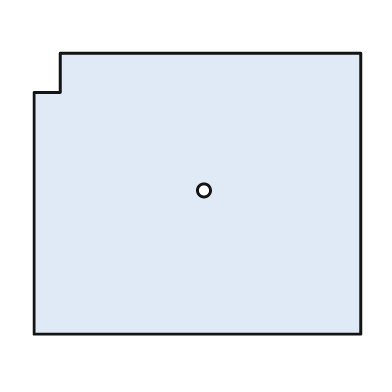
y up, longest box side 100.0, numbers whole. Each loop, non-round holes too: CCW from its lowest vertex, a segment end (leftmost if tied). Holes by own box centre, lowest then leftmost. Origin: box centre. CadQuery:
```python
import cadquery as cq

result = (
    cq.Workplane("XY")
    .moveTo(-50.0, -43.0)
    .lineTo(50.0, -43.0)
    .lineTo(50.0, 43.0)
    .lineTo(-42.0, 43.0)
    .lineTo(-42.0, 31.0)
    .lineTo(-50.0, 31.0)
    .close()
    .moveTo(2.0, 1.0)
    .circle(2.0)
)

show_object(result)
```